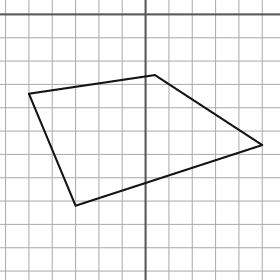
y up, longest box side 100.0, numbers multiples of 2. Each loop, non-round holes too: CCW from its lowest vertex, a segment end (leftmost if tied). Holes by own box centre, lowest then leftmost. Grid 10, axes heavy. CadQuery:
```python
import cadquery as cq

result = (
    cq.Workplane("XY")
    .moveTo(-30.0, -82.0)
    .lineTo(50.0, -56.0)
    .lineTo(4.0, -26.0)
    .lineTo(-50.0, -34.0)
    .close()
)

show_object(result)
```